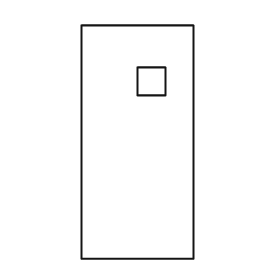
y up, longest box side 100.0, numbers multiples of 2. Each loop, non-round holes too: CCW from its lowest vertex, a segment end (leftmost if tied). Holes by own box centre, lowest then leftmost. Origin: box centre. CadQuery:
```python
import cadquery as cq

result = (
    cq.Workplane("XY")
    .moveTo(-24.0, -50.0)
    .lineTo(24.0, -50.0)
    .lineTo(24.0, 50.0)
    .lineTo(-24.0, 50.0)
    .close()
    .moveTo(0.0, 20.0)
    .lineTo(12.0, 20.0)
    .lineTo(12.0, 32.0)
    .lineTo(0.0, 32.0)
    .close()
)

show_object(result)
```